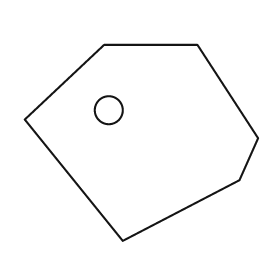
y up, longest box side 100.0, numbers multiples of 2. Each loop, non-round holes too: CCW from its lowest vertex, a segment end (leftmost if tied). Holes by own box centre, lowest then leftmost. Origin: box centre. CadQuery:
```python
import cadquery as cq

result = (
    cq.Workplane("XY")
    .moveTo(-8.0, -42.0)
    .lineTo(42.0, -16.0)
    .lineTo(50.0, 2.0)
    .lineTo(24.0, 42.0)
    .lineTo(-16.0, 42.0)
    .lineTo(-50.0, 10.0)
    .close()
    .moveTo(-14.0, 14.0)
    .circle(6.0)
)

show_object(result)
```